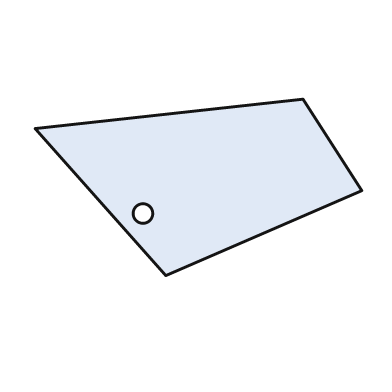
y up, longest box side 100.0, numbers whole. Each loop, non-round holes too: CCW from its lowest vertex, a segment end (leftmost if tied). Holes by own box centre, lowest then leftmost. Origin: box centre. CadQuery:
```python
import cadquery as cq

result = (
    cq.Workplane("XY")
    .moveTo(-10.0, -27.0)
    .lineTo(50.0, -1.0)
    .lineTo(32.0, 27.0)
    .lineTo(-50.0, 18.0)
    .close()
    .moveTo(-17.0, -8.0)
    .circle(3.0)
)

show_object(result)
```